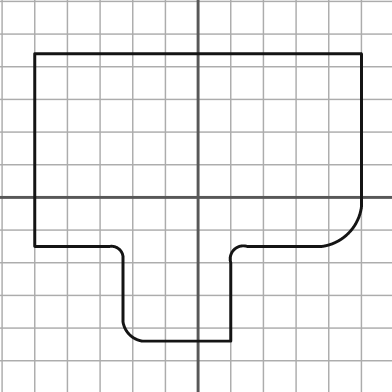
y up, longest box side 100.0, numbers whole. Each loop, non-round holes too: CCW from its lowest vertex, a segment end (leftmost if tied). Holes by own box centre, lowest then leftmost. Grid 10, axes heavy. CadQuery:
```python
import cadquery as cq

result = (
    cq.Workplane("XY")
    .moveTo(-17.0, -44.0)
    .lineTo(10.0, -44.0)
    .lineTo(10.0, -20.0)
    .threePointArc((11.0, -16.0), (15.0, -15.0))
    .lineTo(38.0, -15.0)
    .threePointArc((46.0, -11.0), (50.0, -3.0))
    .lineTo(50.0, 44.0)
    .lineTo(-50.0, 44.0)
    .lineTo(-50.0, -15.0)
    .lineTo(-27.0, -15.0)
    .threePointArc((-24.0, -16.0), (-23.0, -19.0))
    .lineTo(-23.0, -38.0)
    .threePointArc((-21.0, -42.0), (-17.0, -44.0))
    .close()
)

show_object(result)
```